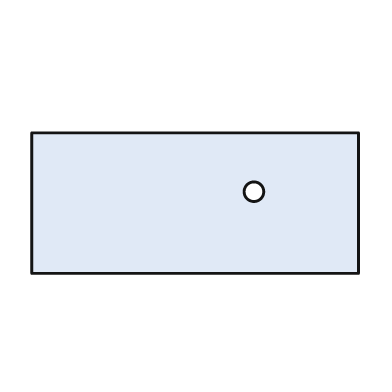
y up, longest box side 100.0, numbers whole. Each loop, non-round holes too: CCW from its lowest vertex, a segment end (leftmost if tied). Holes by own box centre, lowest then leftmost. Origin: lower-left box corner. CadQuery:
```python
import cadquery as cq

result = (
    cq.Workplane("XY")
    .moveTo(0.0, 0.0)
    .lineTo(100.0, 0.0)
    .lineTo(100.0, 43.0)
    .lineTo(0.0, 43.0)
    .close()
    .moveTo(68.0, 25.0)
    .circle(3.0)
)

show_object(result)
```